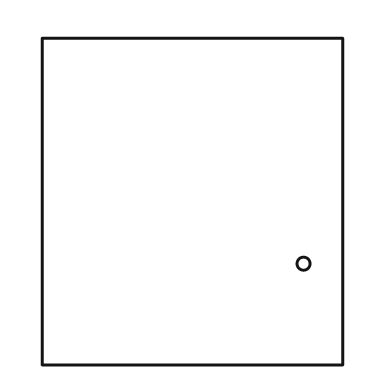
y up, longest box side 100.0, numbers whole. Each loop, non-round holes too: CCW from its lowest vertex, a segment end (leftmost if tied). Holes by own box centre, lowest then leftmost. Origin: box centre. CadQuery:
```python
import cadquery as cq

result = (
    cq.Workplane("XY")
    .moveTo(-46.0, -50.0)
    .lineTo(46.0, -50.0)
    .lineTo(46.0, 50.0)
    .lineTo(-46.0, 50.0)
    .close()
    .moveTo(34.0, -19.0)
    .circle(2.0)
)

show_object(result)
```